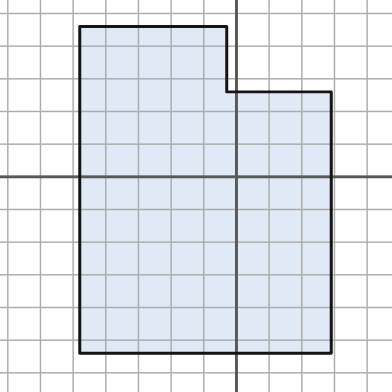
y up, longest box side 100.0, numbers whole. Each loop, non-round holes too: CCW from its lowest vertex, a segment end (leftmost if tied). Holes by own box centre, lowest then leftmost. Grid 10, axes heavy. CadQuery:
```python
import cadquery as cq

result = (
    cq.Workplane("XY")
    .moveTo(-48.0, -54.0)
    .lineTo(29.0, -54.0)
    .lineTo(29.0, 26.0)
    .lineTo(-3.0, 26.0)
    .lineTo(-3.0, 46.0)
    .lineTo(-48.0, 46.0)
    .close()
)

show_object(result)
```